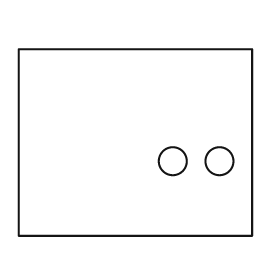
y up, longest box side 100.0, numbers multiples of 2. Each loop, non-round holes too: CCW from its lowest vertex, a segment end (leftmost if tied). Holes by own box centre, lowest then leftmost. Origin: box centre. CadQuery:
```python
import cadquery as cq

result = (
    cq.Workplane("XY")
    .moveTo(-50.0, -40.0)
    .lineTo(50.0, -40.0)
    .lineTo(50.0, 40.0)
    .lineTo(-50.0, 40.0)
    .close()
    .moveTo(16.0, -8.0)
    .circle(6.0)
    .moveTo(36.0, -8.0)
    .circle(6.0)
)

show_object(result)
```